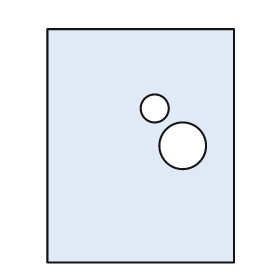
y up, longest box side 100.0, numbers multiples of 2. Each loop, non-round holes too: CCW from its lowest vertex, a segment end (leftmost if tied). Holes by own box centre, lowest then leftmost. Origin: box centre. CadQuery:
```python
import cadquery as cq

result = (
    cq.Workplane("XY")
    .moveTo(-40.0, -50.0)
    .lineTo(40.0, -50.0)
    .lineTo(40.0, 50.0)
    .lineTo(-40.0, 50.0)
    .close()
    .moveTo(18.0, 0.0)
    .circle(10.0)
    .moveTo(6.0, 16.0)
    .circle(6.0)
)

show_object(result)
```